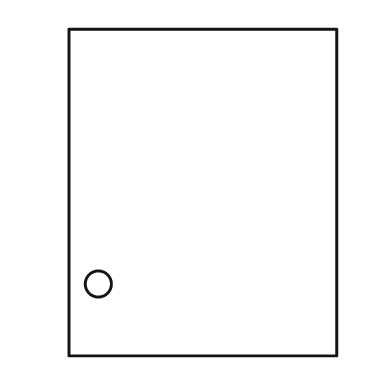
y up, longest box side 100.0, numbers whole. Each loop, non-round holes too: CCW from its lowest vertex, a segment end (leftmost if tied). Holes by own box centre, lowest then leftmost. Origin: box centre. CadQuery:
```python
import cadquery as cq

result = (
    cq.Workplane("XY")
    .moveTo(-41.0, -50.0)
    .lineTo(41.0, -50.0)
    .lineTo(41.0, 50.0)
    .lineTo(-41.0, 50.0)
    .close()
    .moveTo(-32.0, -28.0)
    .circle(4.0)
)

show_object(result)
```